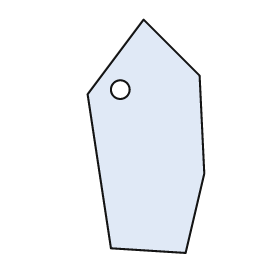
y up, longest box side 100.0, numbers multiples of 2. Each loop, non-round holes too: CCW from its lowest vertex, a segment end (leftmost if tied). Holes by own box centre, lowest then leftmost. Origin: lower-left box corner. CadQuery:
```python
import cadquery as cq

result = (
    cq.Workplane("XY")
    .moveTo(42.0, 0.0)
    .lineTo(50.0, 34.0)
    .lineTo(48.0, 76.0)
    .lineTo(24.0, 100.0)
    .lineTo(0.0, 68.0)
    .lineTo(10.0, 2.0)
    .close()
    .moveTo(14.0, 70.0)
    .circle(4.0)
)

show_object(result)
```